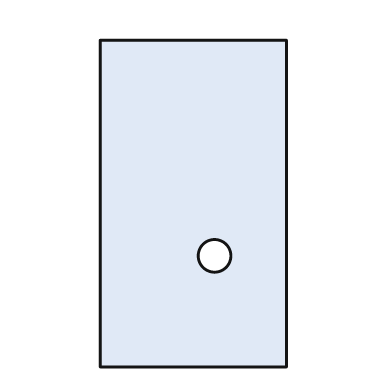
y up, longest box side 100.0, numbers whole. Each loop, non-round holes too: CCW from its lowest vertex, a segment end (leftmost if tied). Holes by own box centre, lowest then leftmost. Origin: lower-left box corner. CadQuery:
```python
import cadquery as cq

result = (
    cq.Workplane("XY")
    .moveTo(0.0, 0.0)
    .lineTo(57.0, 0.0)
    .lineTo(57.0, 100.0)
    .lineTo(0.0, 100.0)
    .close()
    .moveTo(35.0, 34.0)
    .circle(5.0)
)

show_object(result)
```